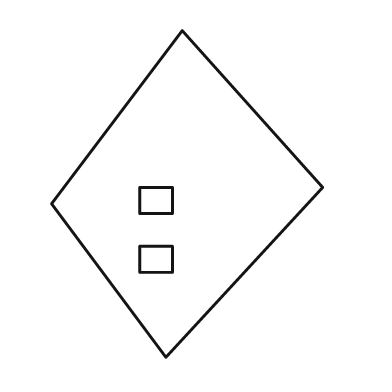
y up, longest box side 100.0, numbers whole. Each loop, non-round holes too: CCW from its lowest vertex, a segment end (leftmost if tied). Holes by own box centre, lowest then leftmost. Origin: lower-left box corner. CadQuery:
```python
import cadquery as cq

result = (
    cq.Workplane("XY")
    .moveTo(35.0, 0.0)
    .lineTo(83.0, 52.0)
    .lineTo(40.0, 100.0)
    .lineTo(0.0, 47.0)
    .close()
    .moveTo(27.0, 26.0)
    .lineTo(37.0, 26.0)
    .lineTo(37.0, 34.0)
    .lineTo(27.0, 34.0)
    .close()
    .moveTo(27.0, 44.0)
    .lineTo(37.0, 44.0)
    .lineTo(37.0, 52.0)
    .lineTo(27.0, 52.0)
    .close()
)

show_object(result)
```